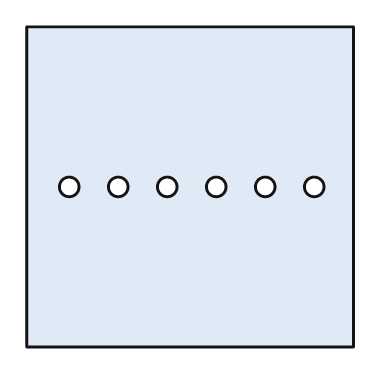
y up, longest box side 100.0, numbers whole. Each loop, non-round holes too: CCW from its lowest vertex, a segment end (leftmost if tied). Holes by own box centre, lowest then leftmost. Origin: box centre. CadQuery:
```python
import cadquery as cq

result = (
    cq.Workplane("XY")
    .moveTo(-50.0, -49.0)
    .lineTo(50.0, -49.0)
    .lineTo(50.0, 49.0)
    .lineTo(-50.0, 49.0)
    .close()
    .moveTo(-37.0, 0.0)
    .circle(3.0)
    .moveTo(-22.0, 0.0)
    .circle(3.0)
    .moveTo(-7.0, 0.0)
    .circle(3.0)
    .moveTo(8.0, 0.0)
    .circle(3.0)
    .moveTo(23.0, 0.0)
    .circle(3.0)
    .moveTo(38.0, 0.0)
    .circle(3.0)
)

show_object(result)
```